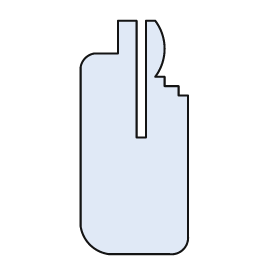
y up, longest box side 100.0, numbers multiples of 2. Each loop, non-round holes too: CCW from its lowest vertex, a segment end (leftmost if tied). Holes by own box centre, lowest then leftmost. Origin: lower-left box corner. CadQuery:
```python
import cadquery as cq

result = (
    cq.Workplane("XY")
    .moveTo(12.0, 0.0)
    .lineTo(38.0, 0.0)
    .threePointArc((44.0, 2.0), (46.0, 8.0))
    .lineTo(46.0, 68.0)
    .lineTo(42.0, 68.0)
    .lineTo(42.0, 72.0)
    .lineTo(36.0, 72.0)
    .lineTo(36.0, 76.0)
    .lineTo(32.0, 76.0)
    .threePointArc((36.0, 88.0), (32.0, 100.0))
    .lineTo(28.0, 100.0)
    .lineTo(28.0, 50.0)
    .lineTo(24.0, 50.0)
    .lineTo(24.0, 100.0)
    .lineTo(16.0, 100.0)
    .lineTo(16.0, 86.0)
    .lineTo(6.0, 86.0)
    .threePointArc((2.0, 84.0), (0.0, 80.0))
    .lineTo(0.0, 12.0)
    .threePointArc((4.0, 4.0), (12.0, 0.0))
    .close()
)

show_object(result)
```